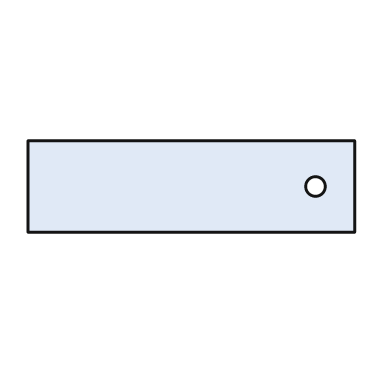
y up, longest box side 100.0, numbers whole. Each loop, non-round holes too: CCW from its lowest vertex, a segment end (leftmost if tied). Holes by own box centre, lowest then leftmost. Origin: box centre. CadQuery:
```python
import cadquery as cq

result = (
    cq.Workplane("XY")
    .moveTo(-50.0, -14.0)
    .lineTo(50.0, -14.0)
    .lineTo(50.0, 14.0)
    .lineTo(-50.0, 14.0)
    .close()
    .moveTo(38.0, 0.0)
    .circle(3.0)
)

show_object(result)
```